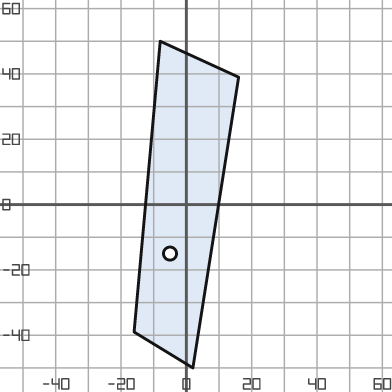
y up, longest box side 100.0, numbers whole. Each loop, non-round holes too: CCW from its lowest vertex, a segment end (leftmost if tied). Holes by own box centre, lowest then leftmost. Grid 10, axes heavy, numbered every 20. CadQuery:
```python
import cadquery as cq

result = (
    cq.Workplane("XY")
    .moveTo(2.0, -50.0)
    .lineTo(16.0, 39.0)
    .lineTo(-8.0, 50.0)
    .lineTo(-16.0, -39.0)
    .close()
    .moveTo(-5.0, -15.0)
    .circle(2.0)
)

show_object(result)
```